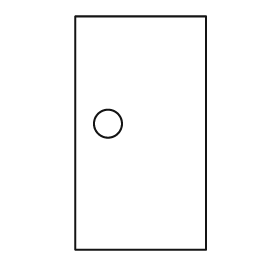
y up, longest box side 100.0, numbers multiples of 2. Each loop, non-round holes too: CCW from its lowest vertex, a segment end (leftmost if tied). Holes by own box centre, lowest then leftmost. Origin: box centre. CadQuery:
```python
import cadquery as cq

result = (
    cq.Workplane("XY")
    .moveTo(-28.0, -50.0)
    .lineTo(28.0, -50.0)
    .lineTo(28.0, 50.0)
    .lineTo(-28.0, 50.0)
    .close()
    .moveTo(-14.0, 4.0)
    .circle(6.0)
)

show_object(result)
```